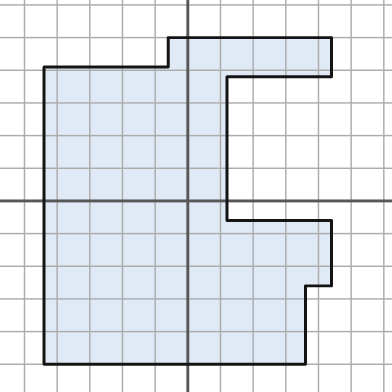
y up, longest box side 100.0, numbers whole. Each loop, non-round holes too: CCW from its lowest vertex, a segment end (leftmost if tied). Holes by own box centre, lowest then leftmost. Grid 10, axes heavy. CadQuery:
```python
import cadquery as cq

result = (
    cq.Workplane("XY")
    .moveTo(-44.0, -50.0)
    .lineTo(36.0, -50.0)
    .lineTo(36.0, -26.0)
    .lineTo(44.0, -26.0)
    .lineTo(44.0, -6.0)
    .lineTo(12.0, -6.0)
    .lineTo(12.0, 38.0)
    .lineTo(44.0, 38.0)
    .lineTo(44.0, 50.0)
    .lineTo(-6.0, 50.0)
    .lineTo(-6.0, 41.0)
    .lineTo(-44.0, 41.0)
    .close()
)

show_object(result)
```